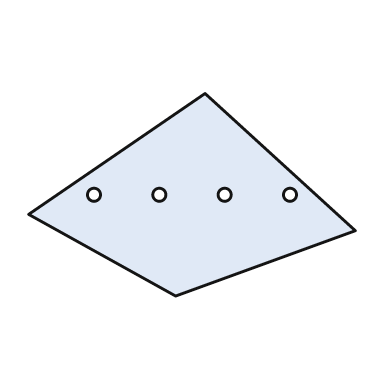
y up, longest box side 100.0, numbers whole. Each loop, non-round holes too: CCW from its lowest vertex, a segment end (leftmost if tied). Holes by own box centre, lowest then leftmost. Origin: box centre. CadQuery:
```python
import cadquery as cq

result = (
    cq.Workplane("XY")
    .moveTo(-5.0, -31.0)
    .lineTo(50.0, -11.0)
    .lineTo(4.0, 31.0)
    .lineTo(-50.0, -6.0)
    .close()
    .moveTo(-30.0, 0.0)
    .circle(2.0)
    .moveTo(-10.0, 0.0)
    .circle(2.0)
    .moveTo(10.0, 0.0)
    .circle(2.0)
    .moveTo(30.0, 0.0)
    .circle(2.0)
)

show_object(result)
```